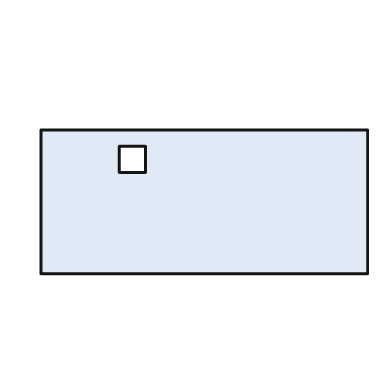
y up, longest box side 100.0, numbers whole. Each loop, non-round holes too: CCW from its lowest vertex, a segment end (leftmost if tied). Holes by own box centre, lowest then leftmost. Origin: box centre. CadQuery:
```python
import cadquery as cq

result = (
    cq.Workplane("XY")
    .moveTo(-50.0, -22.0)
    .lineTo(50.0, -22.0)
    .lineTo(50.0, 22.0)
    .lineTo(-50.0, 22.0)
    .close()
    .moveTo(-26.0, 9.0)
    .lineTo(-18.0, 9.0)
    .lineTo(-18.0, 17.0)
    .lineTo(-26.0, 17.0)
    .close()
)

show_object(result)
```